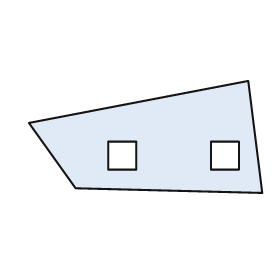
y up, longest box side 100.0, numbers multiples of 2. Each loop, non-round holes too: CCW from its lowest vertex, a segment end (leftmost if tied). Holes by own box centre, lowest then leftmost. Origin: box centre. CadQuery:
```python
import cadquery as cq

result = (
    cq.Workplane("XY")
    .moveTo(50.0, -24.0)
    .lineTo(44.0, 24.0)
    .lineTo(-50.0, 6.0)
    .lineTo(-30.0, -22.0)
    .close()
    .moveTo(-16.0, -14.0)
    .lineTo(-4.0, -14.0)
    .lineTo(-4.0, -2.0)
    .lineTo(-16.0, -2.0)
    .close()
    .moveTo(28.0, -14.0)
    .lineTo(40.0, -14.0)
    .lineTo(40.0, -2.0)
    .lineTo(28.0, -2.0)
    .close()
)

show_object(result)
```